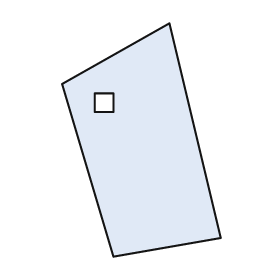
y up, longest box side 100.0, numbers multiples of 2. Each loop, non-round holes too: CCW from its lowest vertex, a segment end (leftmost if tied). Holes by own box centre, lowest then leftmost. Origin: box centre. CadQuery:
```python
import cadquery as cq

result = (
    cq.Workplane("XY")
    .moveTo(-12.0, -50.0)
    .lineTo(34.0, -42.0)
    .lineTo(12.0, 50.0)
    .lineTo(-34.0, 24.0)
    .close()
    .moveTo(-20.0, 12.0)
    .lineTo(-12.0, 12.0)
    .lineTo(-12.0, 20.0)
    .lineTo(-20.0, 20.0)
    .close()
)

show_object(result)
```